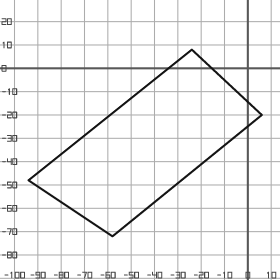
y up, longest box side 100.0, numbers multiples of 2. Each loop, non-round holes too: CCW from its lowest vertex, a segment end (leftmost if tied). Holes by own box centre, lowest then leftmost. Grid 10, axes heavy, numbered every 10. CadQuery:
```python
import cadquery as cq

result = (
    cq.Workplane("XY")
    .moveTo(-58.0, -72.0)
    .lineTo(6.0, -20.0)
    .lineTo(-24.0, 8.0)
    .lineTo(-94.0, -48.0)
    .close()
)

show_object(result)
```